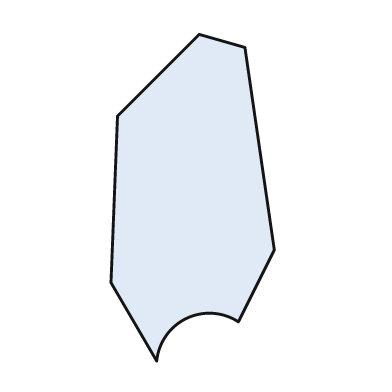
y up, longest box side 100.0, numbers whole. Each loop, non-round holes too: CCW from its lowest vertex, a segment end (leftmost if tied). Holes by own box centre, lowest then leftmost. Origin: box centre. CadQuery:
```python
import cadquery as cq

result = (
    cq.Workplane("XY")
    .moveTo(-11.0, -50.0)
    .threePointArc((-2.0, -37.0), (14.0, -38.0))
    .lineTo(25.0, -16.0)
    .lineTo(16.0, 46.0)
    .lineTo(2.0, 50.0)
    .lineTo(-23.0, 25.0)
    .lineTo(-25.0, -26.0)
    .close()
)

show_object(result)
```